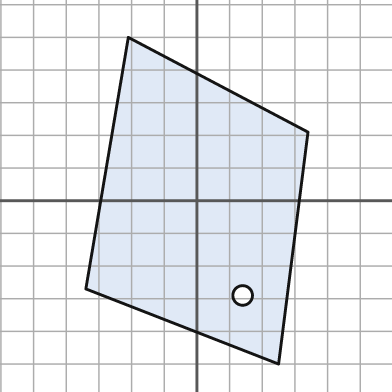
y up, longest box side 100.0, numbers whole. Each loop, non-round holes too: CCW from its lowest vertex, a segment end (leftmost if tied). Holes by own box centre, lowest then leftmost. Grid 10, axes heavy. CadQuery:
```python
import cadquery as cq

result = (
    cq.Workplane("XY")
    .moveTo(25.0, -50.0)
    .lineTo(34.0, 21.0)
    .lineTo(-21.0, 50.0)
    .lineTo(-34.0, -27.0)
    .close()
    .moveTo(14.0, -29.0)
    .circle(3.0)
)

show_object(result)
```